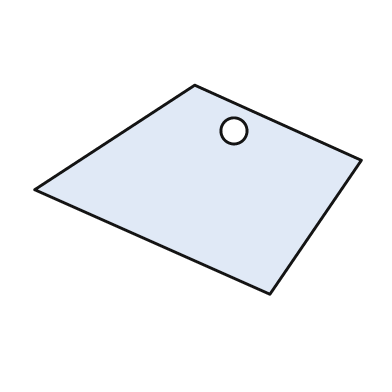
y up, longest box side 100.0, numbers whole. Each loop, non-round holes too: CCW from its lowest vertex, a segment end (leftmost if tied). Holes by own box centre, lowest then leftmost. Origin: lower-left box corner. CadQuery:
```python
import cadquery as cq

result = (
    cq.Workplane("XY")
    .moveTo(72.0, 0.0)
    .lineTo(100.0, 41.0)
    .lineTo(49.0, 64.0)
    .lineTo(0.0, 32.0)
    .close()
    .moveTo(61.0, 50.0)
    .circle(4.0)
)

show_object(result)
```